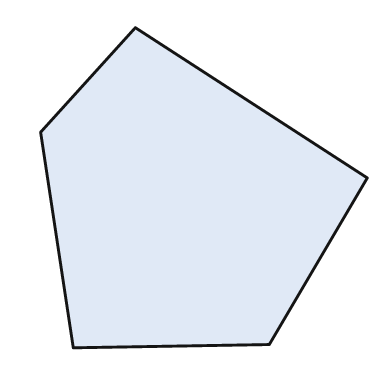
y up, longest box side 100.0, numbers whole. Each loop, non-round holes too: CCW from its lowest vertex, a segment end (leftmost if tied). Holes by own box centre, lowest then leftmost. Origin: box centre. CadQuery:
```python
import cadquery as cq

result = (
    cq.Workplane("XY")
    .moveTo(-40.0, -49.0)
    .lineTo(20.0, -48.0)
    .lineTo(50.0, 3.0)
    .lineTo(-21.0, 49.0)
    .lineTo(-50.0, 17.0)
    .close()
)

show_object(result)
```